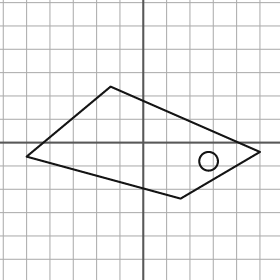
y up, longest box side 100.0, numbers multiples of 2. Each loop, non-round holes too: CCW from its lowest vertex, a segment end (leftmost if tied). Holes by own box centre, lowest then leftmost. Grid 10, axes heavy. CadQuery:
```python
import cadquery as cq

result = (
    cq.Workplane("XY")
    .moveTo(16.0, -24.0)
    .lineTo(50.0, -4.0)
    .lineTo(-14.0, 24.0)
    .lineTo(-50.0, -6.0)
    .close()
    .moveTo(28.0, -8.0)
    .circle(4.0)
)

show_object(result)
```